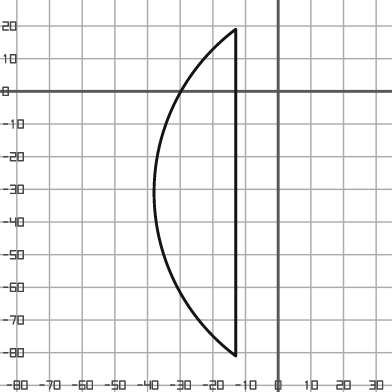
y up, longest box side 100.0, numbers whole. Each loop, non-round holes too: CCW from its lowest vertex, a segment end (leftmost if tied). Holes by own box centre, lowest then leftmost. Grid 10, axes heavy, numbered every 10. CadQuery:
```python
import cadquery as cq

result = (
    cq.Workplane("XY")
    .moveTo(-13.0, -81.0)
    .lineTo(-13.0, 19.0)
    .threePointArc((-38.0, -31.0), (-13.0, -81.0))
    .close()
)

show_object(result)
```